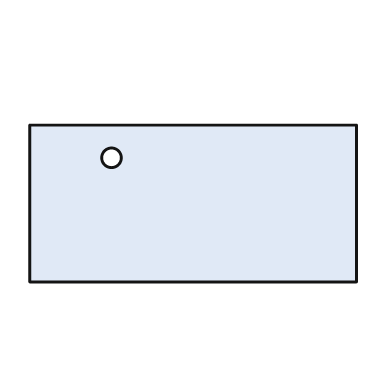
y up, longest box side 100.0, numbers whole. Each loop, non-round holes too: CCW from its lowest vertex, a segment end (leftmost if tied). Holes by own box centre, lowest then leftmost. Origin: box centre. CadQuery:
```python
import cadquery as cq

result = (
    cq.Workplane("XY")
    .moveTo(-50.0, -24.0)
    .lineTo(50.0, -24.0)
    .lineTo(50.0, 24.0)
    .lineTo(-50.0, 24.0)
    .close()
    .moveTo(-25.0, 14.0)
    .circle(3.0)
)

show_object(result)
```